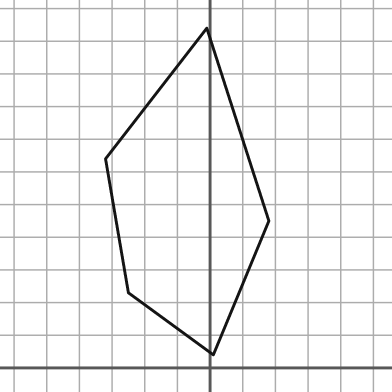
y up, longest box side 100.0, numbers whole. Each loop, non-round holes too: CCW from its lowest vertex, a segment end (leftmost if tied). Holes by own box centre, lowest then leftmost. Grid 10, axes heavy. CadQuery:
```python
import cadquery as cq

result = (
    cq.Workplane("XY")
    .moveTo(1.0, 4.0)
    .lineTo(18.0, 45.0)
    .lineTo(-1.0, 104.0)
    .lineTo(-32.0, 64.0)
    .lineTo(-25.0, 23.0)
    .close()
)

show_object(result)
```